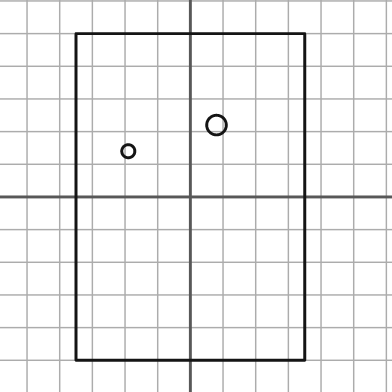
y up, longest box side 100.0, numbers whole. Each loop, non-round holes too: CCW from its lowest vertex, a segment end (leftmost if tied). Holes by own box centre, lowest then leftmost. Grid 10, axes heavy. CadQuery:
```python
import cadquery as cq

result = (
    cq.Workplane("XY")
    .moveTo(-35.0, -50.0)
    .lineTo(35.0, -50.0)
    .lineTo(35.0, 50.0)
    .lineTo(-35.0, 50.0)
    .close()
    .moveTo(-19.0, 14.0)
    .circle(2.0)
    .moveTo(8.0, 22.0)
    .circle(3.0)
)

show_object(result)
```